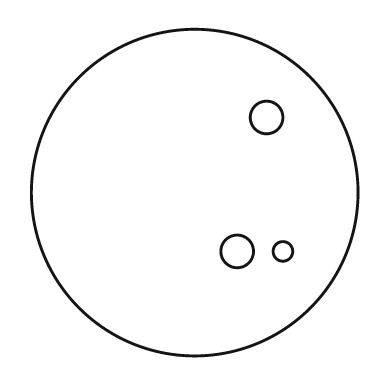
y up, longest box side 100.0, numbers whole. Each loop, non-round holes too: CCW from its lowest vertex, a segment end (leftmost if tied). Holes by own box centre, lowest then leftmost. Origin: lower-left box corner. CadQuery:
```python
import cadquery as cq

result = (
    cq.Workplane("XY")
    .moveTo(50.0, 50.0)
    .circle(50.0)
    .moveTo(63.0, 32.0)
    .circle(5.0)
    .moveTo(77.0, 32.0)
    .circle(3.0)
    .moveTo(72.0, 73.0)
    .circle(5.0)
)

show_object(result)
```